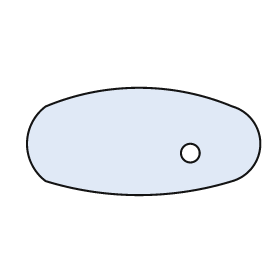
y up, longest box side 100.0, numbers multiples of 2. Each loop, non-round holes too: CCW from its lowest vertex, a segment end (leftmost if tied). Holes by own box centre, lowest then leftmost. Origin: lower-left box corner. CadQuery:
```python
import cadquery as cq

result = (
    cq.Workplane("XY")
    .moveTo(8.0, 6.0)
    .threePointArc((48.0, 0.0), (88.0, 6.0))
    .threePointArc((100.0, 22.0), (88.0, 38.0))
    .threePointArc((48.0, 46.0), (8.0, 38.0))
    .threePointArc((0.0, 22.0), (8.0, 6.0))
    .close()
    .moveTo(70.0, 18.0)
    .circle(4.0)
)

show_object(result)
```